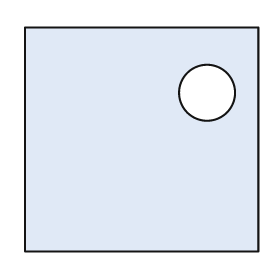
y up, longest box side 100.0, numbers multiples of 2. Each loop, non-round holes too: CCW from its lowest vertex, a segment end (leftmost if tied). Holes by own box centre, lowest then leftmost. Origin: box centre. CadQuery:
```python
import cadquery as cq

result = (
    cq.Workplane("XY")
    .moveTo(-50.0, -48.0)
    .lineTo(50.0, -48.0)
    .lineTo(50.0, 48.0)
    .lineTo(-50.0, 48.0)
    .close()
    .moveTo(28.0, 20.0)
    .circle(12.0)
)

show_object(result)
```